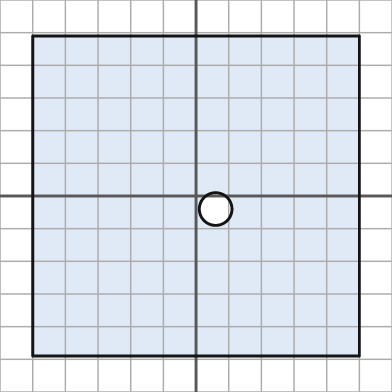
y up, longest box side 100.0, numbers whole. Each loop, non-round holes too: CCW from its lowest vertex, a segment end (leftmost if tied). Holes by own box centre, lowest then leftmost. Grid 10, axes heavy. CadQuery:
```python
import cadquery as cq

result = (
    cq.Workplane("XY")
    .moveTo(-50.0, -49.0)
    .lineTo(50.0, -49.0)
    .lineTo(50.0, 49.0)
    .lineTo(-50.0, 49.0)
    .close()
    .moveTo(6.0, -4.0)
    .circle(5.0)
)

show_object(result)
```